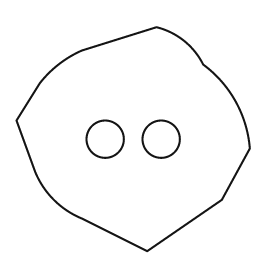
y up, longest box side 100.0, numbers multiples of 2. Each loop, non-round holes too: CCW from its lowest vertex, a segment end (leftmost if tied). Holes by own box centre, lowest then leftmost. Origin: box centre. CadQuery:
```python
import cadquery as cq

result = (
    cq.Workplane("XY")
    .moveTo(6.0, -48.0)
    .lineTo(38.0, -26.0)
    .lineTo(50.0, -4.0)
    .threePointArc((44.0, 16.0), (30.0, 32.0))
    .threePointArc((22.0, 42.0), (10.0, 48.0))
    .lineTo(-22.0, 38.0)
    .threePointArc((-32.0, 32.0), (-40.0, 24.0))
    .lineTo(-50.0, 8.0)
    .lineTo(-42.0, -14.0)
    .threePointArc((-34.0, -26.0), (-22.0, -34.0))
    .close()
    .moveTo(-12.0, 0.0)
    .circle(8.0)
    .moveTo(12.0, 0.0)
    .circle(8.0)
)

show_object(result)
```